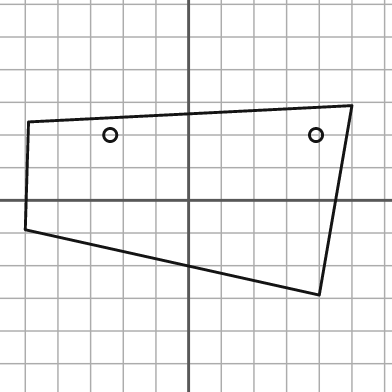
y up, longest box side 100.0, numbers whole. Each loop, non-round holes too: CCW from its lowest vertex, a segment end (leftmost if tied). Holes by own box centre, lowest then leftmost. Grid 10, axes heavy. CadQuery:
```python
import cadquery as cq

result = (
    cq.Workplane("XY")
    .moveTo(40.0, -29.0)
    .lineTo(50.0, 29.0)
    .lineTo(-49.0, 24.0)
    .lineTo(-50.0, -9.0)
    .close()
    .moveTo(-24.0, 20.0)
    .circle(2.0)
    .moveTo(39.0, 20.0)
    .circle(2.0)
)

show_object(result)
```